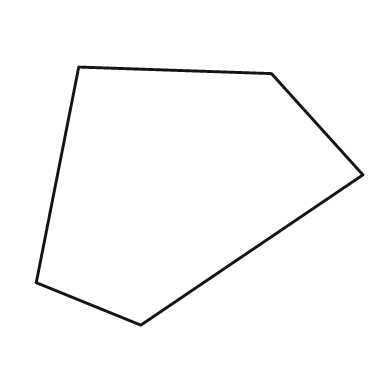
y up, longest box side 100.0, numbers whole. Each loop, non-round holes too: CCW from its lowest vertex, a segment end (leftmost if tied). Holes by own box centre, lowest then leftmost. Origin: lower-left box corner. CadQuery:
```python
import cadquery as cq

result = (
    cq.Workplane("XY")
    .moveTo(32.0, 0.0)
    .lineTo(100.0, 46.0)
    .lineTo(72.0, 77.0)
    .lineTo(13.0, 79.0)
    .lineTo(0.0, 13.0)
    .close()
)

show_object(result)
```